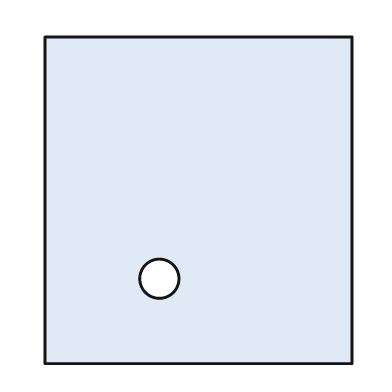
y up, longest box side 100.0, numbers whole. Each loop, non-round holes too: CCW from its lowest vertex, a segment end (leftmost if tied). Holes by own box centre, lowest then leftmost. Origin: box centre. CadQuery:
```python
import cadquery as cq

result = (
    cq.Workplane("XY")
    .moveTo(-47.0, -50.0)
    .lineTo(47.0, -50.0)
    .lineTo(47.0, 50.0)
    .lineTo(-47.0, 50.0)
    .close()
    .moveTo(-12.0, -24.0)
    .circle(6.0)
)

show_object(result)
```